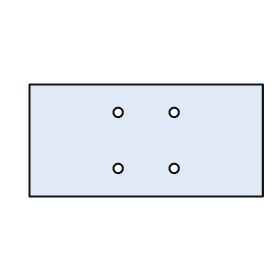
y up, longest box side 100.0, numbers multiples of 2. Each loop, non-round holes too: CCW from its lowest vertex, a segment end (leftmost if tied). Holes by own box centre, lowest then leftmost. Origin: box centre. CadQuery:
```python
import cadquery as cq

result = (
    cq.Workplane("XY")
    .moveTo(-50.0, -24.0)
    .lineTo(50.0, -24.0)
    .lineTo(50.0, 24.0)
    .lineTo(-50.0, 24.0)
    .close()
    .moveTo(-12.0, -12.0)
    .circle(2.0)
    .moveTo(12.0, -12.0)
    .circle(2.0)
    .moveTo(-12.0, 12.0)
    .circle(2.0)
    .moveTo(12.0, 12.0)
    .circle(2.0)
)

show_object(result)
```